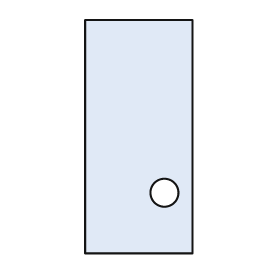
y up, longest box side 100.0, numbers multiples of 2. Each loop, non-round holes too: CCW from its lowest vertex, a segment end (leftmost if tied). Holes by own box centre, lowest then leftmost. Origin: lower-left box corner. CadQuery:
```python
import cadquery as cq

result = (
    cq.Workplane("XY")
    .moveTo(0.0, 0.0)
    .lineTo(46.0, 0.0)
    .lineTo(46.0, 100.0)
    .lineTo(0.0, 100.0)
    .close()
    .moveTo(34.0, 26.0)
    .circle(6.0)
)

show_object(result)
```